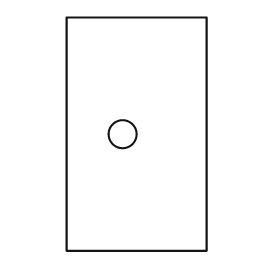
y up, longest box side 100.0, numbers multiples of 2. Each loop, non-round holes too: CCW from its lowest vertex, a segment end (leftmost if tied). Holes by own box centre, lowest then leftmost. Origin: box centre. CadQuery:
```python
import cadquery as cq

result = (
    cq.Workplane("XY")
    .moveTo(-30.0, -50.0)
    .lineTo(30.0, -50.0)
    .lineTo(30.0, 50.0)
    .lineTo(-30.0, 50.0)
    .close()
    .moveTo(-6.0, 0.0)
    .circle(6.0)
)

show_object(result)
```